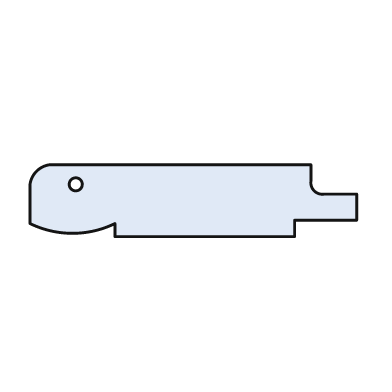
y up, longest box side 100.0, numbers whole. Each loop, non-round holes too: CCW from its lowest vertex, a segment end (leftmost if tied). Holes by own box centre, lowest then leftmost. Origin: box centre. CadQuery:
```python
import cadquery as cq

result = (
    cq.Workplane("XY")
    .moveTo(-24.0, -11.0)
    .lineTo(31.0, -11.0)
    .lineTo(31.0, -6.0)
    .lineTo(50.0, -6.0)
    .lineTo(50.0, 2.0)
    .lineTo(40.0, 2.0)
    .threePointArc((37.0, 3.0), (36.0, 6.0))
    .lineTo(36.0, 11.0)
    .lineTo(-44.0, 11.0)
    .threePointArc((-48.0, 9.0), (-50.0, 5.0))
    .lineTo(-50.0, -7.0)
    .threePointArc((-37.0, -10.0), (-24.0, -7.0))
    .close()
    .moveTo(-36.0, 5.0)
    .circle(2.0)
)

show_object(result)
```